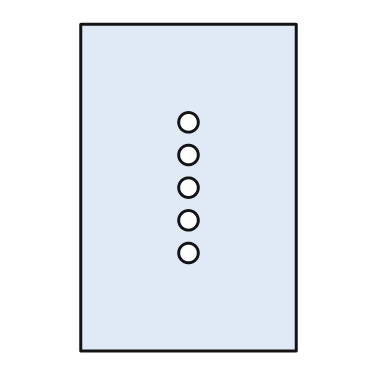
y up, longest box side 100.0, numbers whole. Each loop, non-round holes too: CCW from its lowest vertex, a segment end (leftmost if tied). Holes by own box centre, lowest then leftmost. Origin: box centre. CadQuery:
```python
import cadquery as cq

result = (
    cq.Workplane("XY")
    .moveTo(-33.0, -50.0)
    .lineTo(33.0, -50.0)
    .lineTo(33.0, 50.0)
    .lineTo(-33.0, 50.0)
    .close()
    .moveTo(0.0, -20.0)
    .circle(3.0)
    .moveTo(0.0, -10.0)
    .circle(3.0)
    .moveTo(0.0, 0.0)
    .circle(3.0)
    .moveTo(0.0, 10.0)
    .circle(3.0)
    .moveTo(0.0, 20.0)
    .circle(3.0)
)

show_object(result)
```